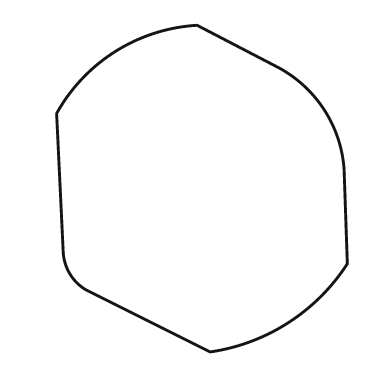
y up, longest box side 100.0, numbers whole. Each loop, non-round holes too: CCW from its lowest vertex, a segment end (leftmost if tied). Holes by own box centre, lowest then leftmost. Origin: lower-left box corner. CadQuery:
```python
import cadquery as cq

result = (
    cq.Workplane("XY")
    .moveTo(47.0, 0.0)
    .threePointArc((71.0, 9.0), (89.0, 27.0))
    .lineTo(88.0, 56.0)
    .threePointArc((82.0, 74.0), (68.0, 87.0))
    .lineTo(43.0, 100.0)
    .threePointArc((18.0, 92.0), (0.0, 73.0))
    .lineTo(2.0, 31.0)
    .threePointArc((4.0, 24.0), (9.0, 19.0))
    .close()
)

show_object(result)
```